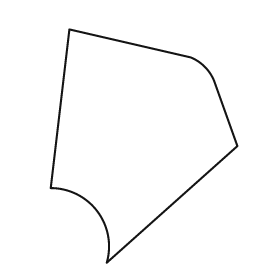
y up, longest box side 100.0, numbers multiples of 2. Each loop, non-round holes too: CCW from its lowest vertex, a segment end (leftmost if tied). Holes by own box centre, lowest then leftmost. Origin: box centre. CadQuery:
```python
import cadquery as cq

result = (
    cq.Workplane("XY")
    .moveTo(-16.0, -50.0)
    .lineTo(40.0, 0.0)
    .lineTo(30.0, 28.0)
    .threePointArc((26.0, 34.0), (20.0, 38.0))
    .lineTo(-32.0, 50.0)
    .lineTo(-40.0, -18.0)
    .threePointArc((-20.0, -28.0), (-16.0, -50.0))
    .close()
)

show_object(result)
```